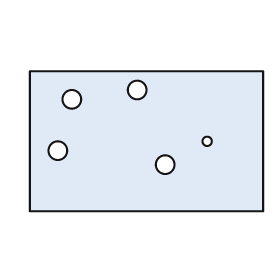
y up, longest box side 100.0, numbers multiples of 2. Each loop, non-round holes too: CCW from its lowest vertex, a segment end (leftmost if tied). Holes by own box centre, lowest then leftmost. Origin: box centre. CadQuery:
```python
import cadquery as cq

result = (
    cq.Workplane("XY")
    .moveTo(-50.0, -30.0)
    .lineTo(50.0, -30.0)
    .lineTo(50.0, 30.0)
    .lineTo(-50.0, 30.0)
    .close()
    .moveTo(8.0, -10.0)
    .circle(4.0)
    .moveTo(-38.0, -4.0)
    .circle(4.0)
    .moveTo(26.0, 0.0)
    .circle(2.0)
    .moveTo(-32.0, 18.0)
    .circle(4.0)
    .moveTo(-4.0, 22.0)
    .circle(4.0)
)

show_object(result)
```